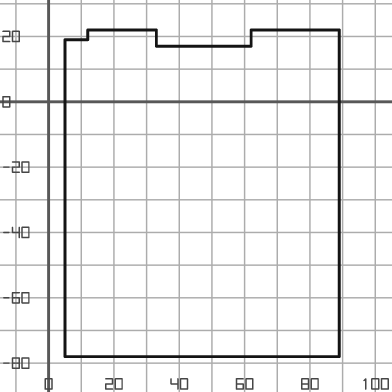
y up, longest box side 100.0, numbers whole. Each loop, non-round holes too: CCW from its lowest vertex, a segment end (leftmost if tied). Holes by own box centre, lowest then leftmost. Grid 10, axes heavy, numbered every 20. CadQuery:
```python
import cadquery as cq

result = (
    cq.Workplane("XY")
    .moveTo(5.0, -78.0)
    .lineTo(89.0, -78.0)
    .lineTo(89.0, 22.0)
    .lineTo(62.0, 22.0)
    .lineTo(62.0, 17.0)
    .lineTo(33.0, 17.0)
    .lineTo(33.0, 22.0)
    .lineTo(12.0, 22.0)
    .lineTo(12.0, 19.0)
    .lineTo(5.0, 19.0)
    .close()
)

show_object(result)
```